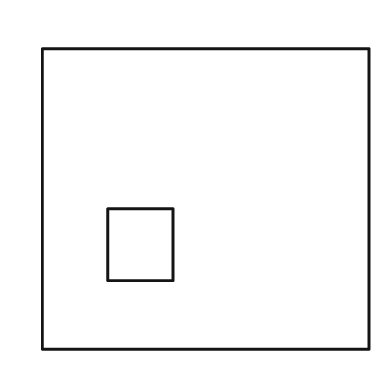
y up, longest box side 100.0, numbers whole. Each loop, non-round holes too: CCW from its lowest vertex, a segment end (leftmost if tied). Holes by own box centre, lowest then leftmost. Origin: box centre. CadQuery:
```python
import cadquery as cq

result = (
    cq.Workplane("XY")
    .moveTo(-50.0, -46.0)
    .lineTo(50.0, -46.0)
    .lineTo(50.0, 46.0)
    .lineTo(-50.0, 46.0)
    .close()
    .moveTo(-30.0, -25.0)
    .lineTo(-10.0, -25.0)
    .lineTo(-10.0, -3.0)
    .lineTo(-30.0, -3.0)
    .close()
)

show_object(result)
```